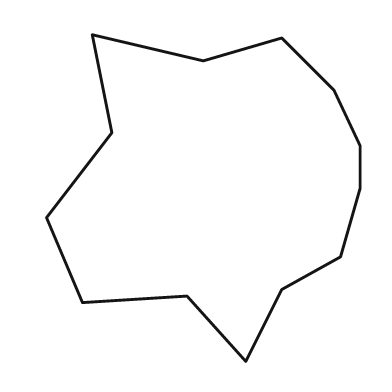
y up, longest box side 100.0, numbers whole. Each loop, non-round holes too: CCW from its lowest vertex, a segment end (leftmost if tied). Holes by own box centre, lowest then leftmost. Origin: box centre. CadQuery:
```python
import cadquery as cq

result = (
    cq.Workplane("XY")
    .moveTo(13.0, -50.0)
    .lineTo(24.0, -28.0)
    .lineTo(42.0, -18.0)
    .lineTo(48.0, 3.0)
    .lineTo(48.0, 16.0)
    .lineTo(40.0, 33.0)
    .lineTo(24.0, 49.0)
    .lineTo(0.0, 42.0)
    .lineTo(-34.0, 50.0)
    .lineTo(-28.0, 20.0)
    .lineTo(-48.0, -6.0)
    .lineTo(-37.0, -32.0)
    .lineTo(-5.0, -30.0)
    .close()
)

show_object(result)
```